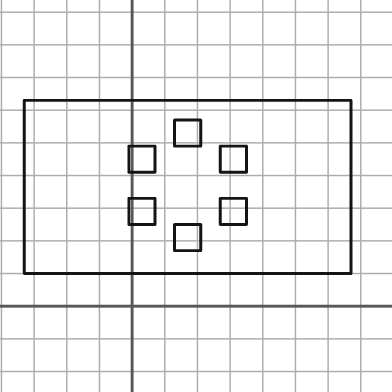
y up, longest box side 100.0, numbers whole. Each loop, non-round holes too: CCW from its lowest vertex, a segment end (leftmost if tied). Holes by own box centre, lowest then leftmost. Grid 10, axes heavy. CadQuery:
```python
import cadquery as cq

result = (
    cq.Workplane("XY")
    .moveTo(-33.0, 10.0)
    .lineTo(67.0, 10.0)
    .lineTo(67.0, 63.0)
    .lineTo(-33.0, 63.0)
    .close()
    .moveTo(13.0, 17.0)
    .lineTo(21.0, 17.0)
    .lineTo(21.0, 25.0)
    .lineTo(13.0, 25.0)
    .close()
    .moveTo(-1.0, 25.0)
    .lineTo(7.0, 25.0)
    .lineTo(7.0, 33.0)
    .lineTo(-1.0, 33.0)
    .close()
    .moveTo(27.0, 25.0)
    .lineTo(35.0, 25.0)
    .lineTo(35.0, 33.0)
    .lineTo(27.0, 33.0)
    .close()
    .moveTo(-1.0, 41.0)
    .lineTo(7.0, 41.0)
    .lineTo(7.0, 49.0)
    .lineTo(-1.0, 49.0)
    .close()
    .moveTo(27.0, 41.0)
    .lineTo(35.0, 41.0)
    .lineTo(35.0, 49.0)
    .lineTo(27.0, 49.0)
    .close()
    .moveTo(13.0, 49.0)
    .lineTo(21.0, 49.0)
    .lineTo(21.0, 57.0)
    .lineTo(13.0, 57.0)
    .close()
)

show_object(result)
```